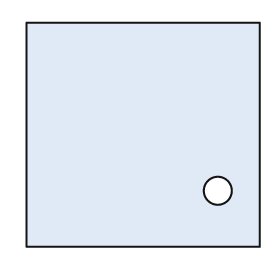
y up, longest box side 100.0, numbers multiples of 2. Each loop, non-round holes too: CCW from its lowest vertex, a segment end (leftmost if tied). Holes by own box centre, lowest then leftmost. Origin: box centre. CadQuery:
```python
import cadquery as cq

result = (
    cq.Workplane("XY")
    .moveTo(-50.0, -48.0)
    .lineTo(50.0, -48.0)
    .lineTo(50.0, 48.0)
    .lineTo(-50.0, 48.0)
    .close()
    .moveTo(32.0, -24.0)
    .circle(6.0)
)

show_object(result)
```